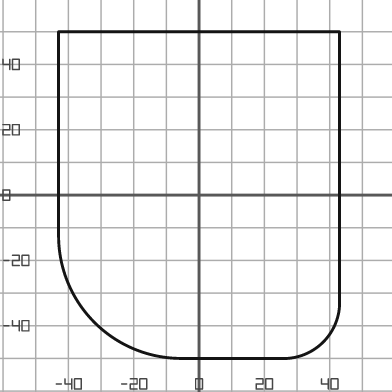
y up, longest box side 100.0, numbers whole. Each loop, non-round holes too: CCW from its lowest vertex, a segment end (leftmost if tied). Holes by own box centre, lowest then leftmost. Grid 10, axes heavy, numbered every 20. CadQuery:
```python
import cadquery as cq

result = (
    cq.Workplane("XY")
    .moveTo(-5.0, -50.0)
    .lineTo(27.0, -50.0)
    .threePointArc((38.0, -45.0), (43.0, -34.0))
    .lineTo(43.0, 50.0)
    .lineTo(-43.0, 50.0)
    .lineTo(-43.0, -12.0)
    .threePointArc((-32.0, -39.0), (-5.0, -50.0))
    .close()
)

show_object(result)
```